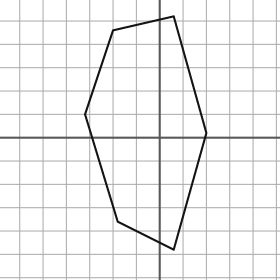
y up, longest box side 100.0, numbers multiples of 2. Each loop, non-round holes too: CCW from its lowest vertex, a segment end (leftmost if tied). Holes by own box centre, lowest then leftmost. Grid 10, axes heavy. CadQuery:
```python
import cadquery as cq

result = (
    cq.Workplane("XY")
    .moveTo(6.0, -48.0)
    .lineTo(20.0, 2.0)
    .lineTo(6.0, 52.0)
    .lineTo(-20.0, 46.0)
    .lineTo(-32.0, 10.0)
    .lineTo(-18.0, -36.0)
    .close()
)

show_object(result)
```